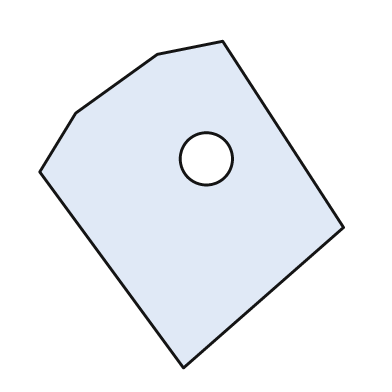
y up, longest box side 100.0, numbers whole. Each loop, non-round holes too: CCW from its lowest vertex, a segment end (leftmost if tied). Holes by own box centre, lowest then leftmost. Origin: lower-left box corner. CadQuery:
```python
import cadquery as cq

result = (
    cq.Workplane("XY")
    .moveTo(44.0, 0.0)
    .lineTo(93.0, 43.0)
    .lineTo(56.0, 100.0)
    .lineTo(36.0, 96.0)
    .lineTo(11.0, 78.0)
    .lineTo(0.0, 60.0)
    .close()
    .moveTo(51.0, 64.0)
    .circle(8.0)
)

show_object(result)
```